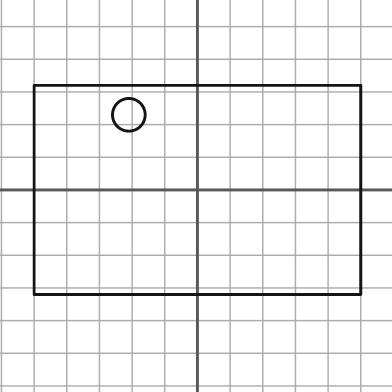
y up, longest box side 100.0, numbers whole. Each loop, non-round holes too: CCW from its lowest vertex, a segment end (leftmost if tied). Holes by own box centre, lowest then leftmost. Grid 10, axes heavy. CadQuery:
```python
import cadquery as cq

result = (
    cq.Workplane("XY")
    .moveTo(-50.0, -32.0)
    .lineTo(50.0, -32.0)
    .lineTo(50.0, 32.0)
    .lineTo(-50.0, 32.0)
    .close()
    .moveTo(-21.0, 23.0)
    .circle(5.0)
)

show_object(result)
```